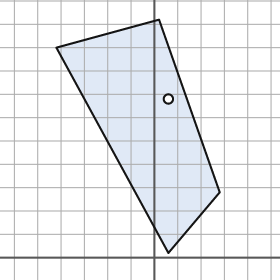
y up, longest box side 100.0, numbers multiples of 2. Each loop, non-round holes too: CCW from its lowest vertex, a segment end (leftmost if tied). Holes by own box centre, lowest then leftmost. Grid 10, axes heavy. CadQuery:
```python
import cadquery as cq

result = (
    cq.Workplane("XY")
    .moveTo(6.0, 2.0)
    .lineTo(28.0, 28.0)
    .lineTo(2.0, 102.0)
    .lineTo(-42.0, 90.0)
    .close()
    .moveTo(6.0, 68.0)
    .circle(2.0)
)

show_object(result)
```